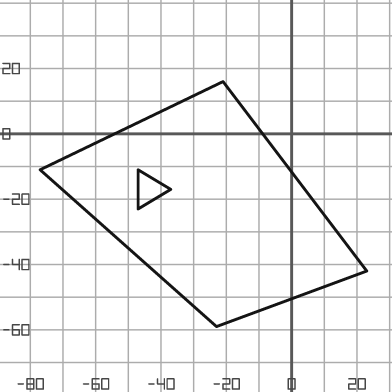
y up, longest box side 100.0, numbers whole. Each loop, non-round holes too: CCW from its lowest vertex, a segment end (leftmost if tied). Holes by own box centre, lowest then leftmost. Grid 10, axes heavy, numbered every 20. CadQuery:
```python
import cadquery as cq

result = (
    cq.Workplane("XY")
    .moveTo(-23.0, -59.0)
    .lineTo(23.0, -42.0)
    .lineTo(-21.0, 16.0)
    .lineTo(-77.0, -11.0)
    .close()
    .moveTo(-47.0, -23.0)
    .lineTo(-37.0, -17.0)
    .lineTo(-47.0, -11.0)
    .close()
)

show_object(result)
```